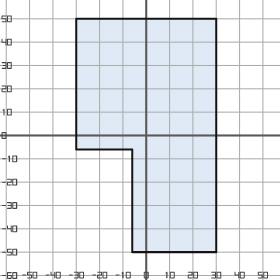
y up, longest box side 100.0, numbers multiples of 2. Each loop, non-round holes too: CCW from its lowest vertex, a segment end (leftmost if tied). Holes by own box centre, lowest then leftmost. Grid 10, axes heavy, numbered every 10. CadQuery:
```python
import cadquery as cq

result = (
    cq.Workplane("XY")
    .moveTo(-6.0, -50.0)
    .lineTo(30.0, -50.0)
    .lineTo(30.0, 50.0)
    .lineTo(-30.0, 50.0)
    .lineTo(-30.0, -6.0)
    .lineTo(-6.0, -6.0)
    .close()
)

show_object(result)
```